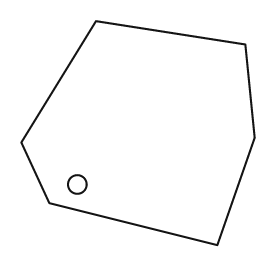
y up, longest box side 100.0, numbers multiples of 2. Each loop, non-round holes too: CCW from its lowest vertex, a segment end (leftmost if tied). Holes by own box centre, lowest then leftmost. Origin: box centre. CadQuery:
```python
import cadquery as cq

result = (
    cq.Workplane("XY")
    .moveTo(34.0, -48.0)
    .lineTo(50.0, -2.0)
    .lineTo(46.0, 38.0)
    .lineTo(-18.0, 48.0)
    .lineTo(-50.0, -4.0)
    .lineTo(-38.0, -30.0)
    .close()
    .moveTo(-26.0, -22.0)
    .circle(4.0)
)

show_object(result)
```